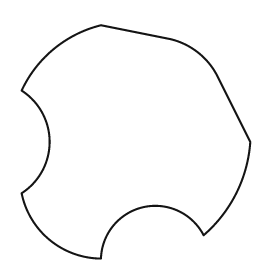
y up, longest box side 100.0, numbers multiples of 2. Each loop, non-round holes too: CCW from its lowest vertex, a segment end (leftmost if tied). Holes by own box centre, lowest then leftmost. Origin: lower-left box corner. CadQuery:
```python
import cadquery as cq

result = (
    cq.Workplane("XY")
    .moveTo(34.0, 0.0)
    .threePointArc((52.0, 22.0), (78.0, 10.0))
    .threePointArc((92.0, 28.0), (98.0, 50.0))
    .lineTo(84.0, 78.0)
    .threePointArc((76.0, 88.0), (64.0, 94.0))
    .lineTo(34.0, 100.0)
    .threePointArc((14.0, 90.0), (0.0, 72.0))
    .threePointArc((12.0, 50.0), (0.0, 28.0))
    .threePointArc((12.0, 8.0), (34.0, 0.0))
    .close()
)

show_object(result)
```